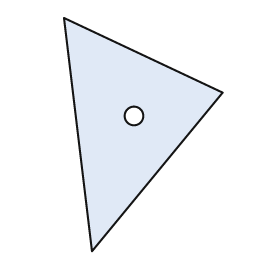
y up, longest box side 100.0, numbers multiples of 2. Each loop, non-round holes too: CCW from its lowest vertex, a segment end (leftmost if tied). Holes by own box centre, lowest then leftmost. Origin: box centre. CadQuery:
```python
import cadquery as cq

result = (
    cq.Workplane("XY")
    .moveTo(-22.0, -50.0)
    .lineTo(34.0, 18.0)
    .lineTo(-34.0, 50.0)
    .close()
    .moveTo(-4.0, 8.0)
    .circle(4.0)
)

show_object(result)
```